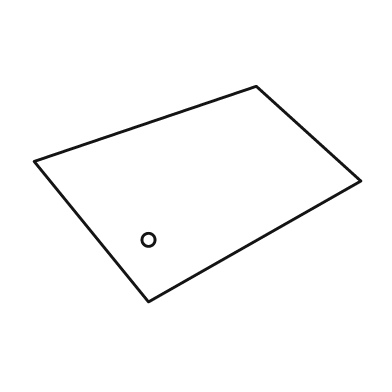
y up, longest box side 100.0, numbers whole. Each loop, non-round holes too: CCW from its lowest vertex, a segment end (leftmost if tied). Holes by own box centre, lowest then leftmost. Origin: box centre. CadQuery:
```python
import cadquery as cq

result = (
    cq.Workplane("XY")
    .moveTo(-15.0, -33.0)
    .lineTo(50.0, 4.0)
    .lineTo(18.0, 33.0)
    .lineTo(-50.0, 10.0)
    .close()
    .moveTo(-15.0, -14.0)
    .circle(2.0)
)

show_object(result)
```